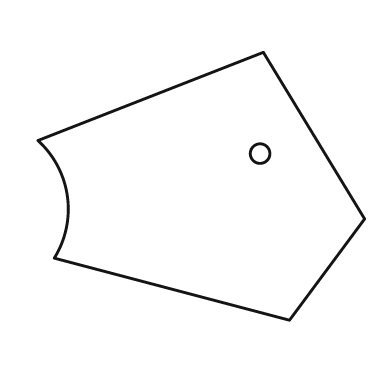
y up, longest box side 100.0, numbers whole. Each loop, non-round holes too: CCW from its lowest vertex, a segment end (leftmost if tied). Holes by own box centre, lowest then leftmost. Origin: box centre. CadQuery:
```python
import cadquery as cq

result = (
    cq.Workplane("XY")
    .moveTo(27.0, -41.0)
    .lineTo(50.0, -10.0)
    .lineTo(19.0, 41.0)
    .lineTo(-50.0, 14.0)
    .threePointArc((-41.0, -3.0), (-45.0, -22.0))
    .close()
    .moveTo(18.0, 10.0)
    .circle(3.0)
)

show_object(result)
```